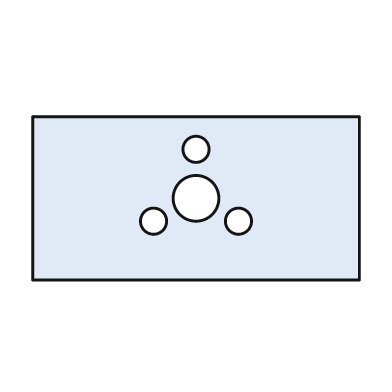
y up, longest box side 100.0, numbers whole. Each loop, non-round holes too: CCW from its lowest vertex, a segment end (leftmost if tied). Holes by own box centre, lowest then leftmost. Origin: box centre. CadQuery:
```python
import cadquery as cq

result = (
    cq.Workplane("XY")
    .moveTo(-50.0, -25.0)
    .lineTo(50.0, -25.0)
    .lineTo(50.0, 25.0)
    .lineTo(-50.0, 25.0)
    .close()
    .moveTo(-13.0, -7.0)
    .circle(4.0)
    .moveTo(13.0, -7.0)
    .circle(4.0)
    .moveTo(0.0, 0.0)
    .circle(7.0)
    .moveTo(0.0, 15.0)
    .circle(4.0)
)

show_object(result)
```